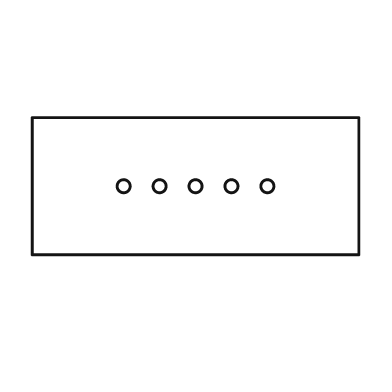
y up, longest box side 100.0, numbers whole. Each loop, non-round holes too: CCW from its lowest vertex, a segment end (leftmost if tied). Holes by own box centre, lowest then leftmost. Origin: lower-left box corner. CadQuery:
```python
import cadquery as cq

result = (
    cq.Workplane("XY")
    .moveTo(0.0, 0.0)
    .lineTo(100.0, 0.0)
    .lineTo(100.0, 42.0)
    .lineTo(0.0, 42.0)
    .close()
    .moveTo(28.0, 21.0)
    .circle(2.0)
    .moveTo(39.0, 21.0)
    .circle(2.0)
    .moveTo(50.0, 21.0)
    .circle(2.0)
    .moveTo(61.0, 21.0)
    .circle(2.0)
    .moveTo(72.0, 21.0)
    .circle(2.0)
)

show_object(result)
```